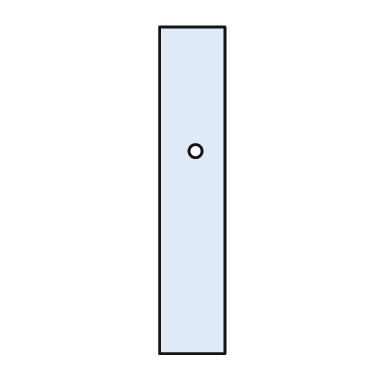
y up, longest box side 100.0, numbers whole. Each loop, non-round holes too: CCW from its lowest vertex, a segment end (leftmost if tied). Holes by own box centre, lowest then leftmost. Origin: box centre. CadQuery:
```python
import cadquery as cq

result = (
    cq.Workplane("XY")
    .moveTo(-10.0, -50.0)
    .lineTo(10.0, -50.0)
    .lineTo(10.0, 50.0)
    .lineTo(-10.0, 50.0)
    .close()
    .moveTo(1.0, 12.0)
    .circle(2.0)
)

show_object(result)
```